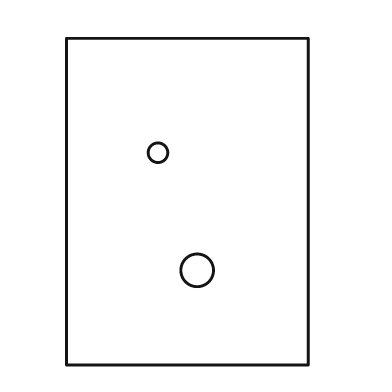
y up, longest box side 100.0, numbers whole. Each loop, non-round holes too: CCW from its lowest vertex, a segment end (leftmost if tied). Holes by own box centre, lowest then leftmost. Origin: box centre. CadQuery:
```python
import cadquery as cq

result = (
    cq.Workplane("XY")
    .moveTo(-37.0, -50.0)
    .lineTo(37.0, -50.0)
    .lineTo(37.0, 50.0)
    .lineTo(-37.0, 50.0)
    .close()
    .moveTo(3.0, -21.0)
    .circle(5.0)
    .moveTo(-9.0, 15.0)
    .circle(3.0)
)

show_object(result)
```